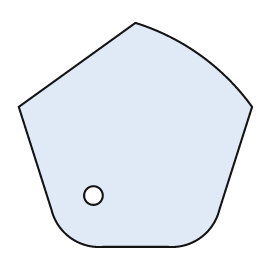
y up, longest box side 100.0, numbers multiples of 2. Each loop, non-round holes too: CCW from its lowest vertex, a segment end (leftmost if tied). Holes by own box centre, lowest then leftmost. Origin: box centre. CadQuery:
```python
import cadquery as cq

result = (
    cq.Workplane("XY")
    .moveTo(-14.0, -48.0)
    .lineTo(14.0, -48.0)
    .threePointArc((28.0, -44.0), (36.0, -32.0))
    .lineTo(50.0, 12.0)
    .threePointArc((28.0, 34.0), (0.0, 48.0))
    .lineTo(-50.0, 12.0)
    .lineTo(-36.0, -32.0)
    .threePointArc((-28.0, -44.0), (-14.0, -48.0))
    .close()
    .moveTo(-18.0, -26.0)
    .circle(4.0)
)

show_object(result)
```